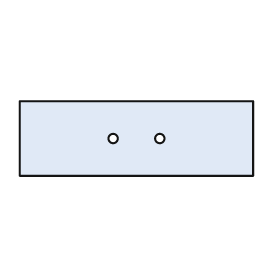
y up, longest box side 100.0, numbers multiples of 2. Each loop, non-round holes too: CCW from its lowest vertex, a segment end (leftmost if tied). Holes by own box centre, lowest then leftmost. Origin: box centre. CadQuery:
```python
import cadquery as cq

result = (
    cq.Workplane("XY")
    .moveTo(-50.0, -16.0)
    .lineTo(50.0, -16.0)
    .lineTo(50.0, 16.0)
    .lineTo(-50.0, 16.0)
    .close()
    .moveTo(-10.0, 0.0)
    .circle(2.0)
    .moveTo(10.0, 0.0)
    .circle(2.0)
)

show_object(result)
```